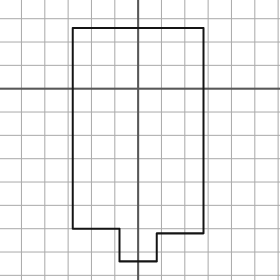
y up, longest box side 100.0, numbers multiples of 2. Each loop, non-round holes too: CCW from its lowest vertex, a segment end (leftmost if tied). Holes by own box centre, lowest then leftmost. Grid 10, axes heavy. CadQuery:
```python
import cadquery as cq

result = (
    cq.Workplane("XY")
    .moveTo(-8.0, -74.0)
    .lineTo(8.0, -74.0)
    .lineTo(8.0, -62.0)
    .lineTo(28.0, -62.0)
    .lineTo(28.0, 26.0)
    .lineTo(-28.0, 26.0)
    .lineTo(-28.0, -60.0)
    .lineTo(-8.0, -60.0)
    .close()
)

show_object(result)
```